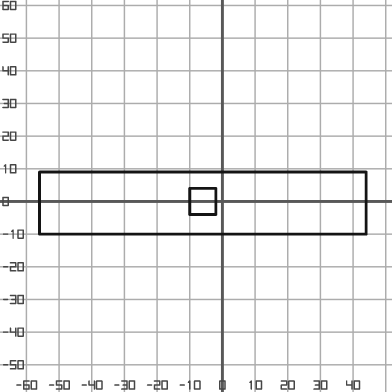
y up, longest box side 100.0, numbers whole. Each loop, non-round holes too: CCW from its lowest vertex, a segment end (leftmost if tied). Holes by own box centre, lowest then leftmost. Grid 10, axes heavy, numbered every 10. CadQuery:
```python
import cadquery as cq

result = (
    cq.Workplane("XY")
    .moveTo(-56.0, -10.0)
    .lineTo(44.0, -10.0)
    .lineTo(44.0, 9.0)
    .lineTo(-56.0, 9.0)
    .close()
    .moveTo(-10.0, -4.0)
    .lineTo(-2.0, -4.0)
    .lineTo(-2.0, 4.0)
    .lineTo(-10.0, 4.0)
    .close()
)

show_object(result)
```